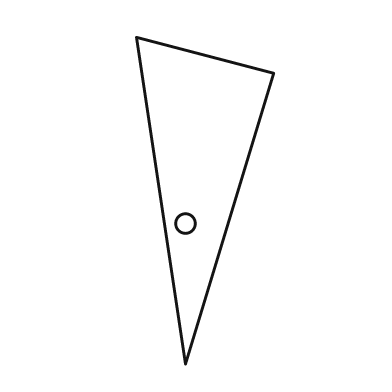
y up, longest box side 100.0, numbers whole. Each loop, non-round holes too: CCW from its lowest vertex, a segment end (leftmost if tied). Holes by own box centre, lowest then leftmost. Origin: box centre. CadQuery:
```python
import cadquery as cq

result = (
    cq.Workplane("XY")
    .moveTo(-6.0, -50.0)
    .lineTo(21.0, 39.0)
    .lineTo(-21.0, 50.0)
    .close()
    .moveTo(-6.0, -7.0)
    .circle(3.0)
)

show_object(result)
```